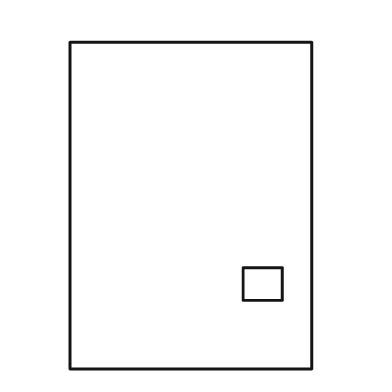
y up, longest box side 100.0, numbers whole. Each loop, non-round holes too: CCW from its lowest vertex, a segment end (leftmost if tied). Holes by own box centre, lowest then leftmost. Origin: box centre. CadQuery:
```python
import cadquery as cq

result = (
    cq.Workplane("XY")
    .moveTo(-37.0, -50.0)
    .lineTo(37.0, -50.0)
    .lineTo(37.0, 50.0)
    .lineTo(-37.0, 50.0)
    .close()
    .moveTo(16.0, -29.0)
    .lineTo(28.0, -29.0)
    .lineTo(28.0, -19.0)
    .lineTo(16.0, -19.0)
    .close()
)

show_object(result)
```